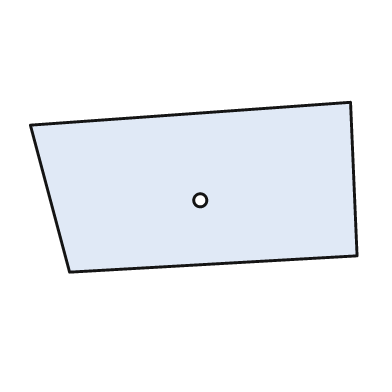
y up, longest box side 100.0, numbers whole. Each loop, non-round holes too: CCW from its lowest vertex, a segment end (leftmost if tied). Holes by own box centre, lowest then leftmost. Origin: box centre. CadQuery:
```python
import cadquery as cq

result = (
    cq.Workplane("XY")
    .moveTo(-38.0, -26.0)
    .lineTo(50.0, -21.0)
    .lineTo(48.0, 26.0)
    .lineTo(-50.0, 19.0)
    .close()
    .moveTo(2.0, -4.0)
    .circle(2.0)
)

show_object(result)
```